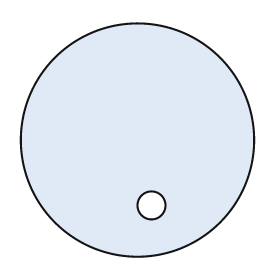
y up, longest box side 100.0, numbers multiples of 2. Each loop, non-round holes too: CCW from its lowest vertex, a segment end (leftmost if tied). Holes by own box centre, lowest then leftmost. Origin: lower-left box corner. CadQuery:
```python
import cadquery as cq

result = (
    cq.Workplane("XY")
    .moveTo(50.0, 50.0)
    .circle(50.0)
    .moveTo(56.0, 22.0)
    .circle(6.0)
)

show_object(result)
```